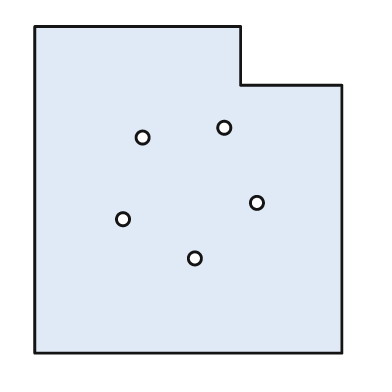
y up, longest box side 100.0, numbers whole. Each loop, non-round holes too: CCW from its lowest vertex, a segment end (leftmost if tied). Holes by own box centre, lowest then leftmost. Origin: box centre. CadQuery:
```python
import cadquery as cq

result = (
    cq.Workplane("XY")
    .moveTo(-47.0, -50.0)
    .lineTo(47.0, -50.0)
    .lineTo(47.0, 32.0)
    .lineTo(16.0, 32.0)
    .lineTo(16.0, 50.0)
    .lineTo(-47.0, 50.0)
    .close()
    .moveTo(2.0, -21.0)
    .circle(2.0)
    .moveTo(-20.0, -9.0)
    .circle(2.0)
    .moveTo(21.0, -4.0)
    .circle(2.0)
    .moveTo(-14.0, 16.0)
    .circle(2.0)
    .moveTo(11.0, 19.0)
    .circle(2.0)
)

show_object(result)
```